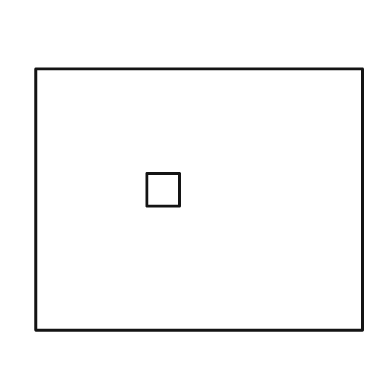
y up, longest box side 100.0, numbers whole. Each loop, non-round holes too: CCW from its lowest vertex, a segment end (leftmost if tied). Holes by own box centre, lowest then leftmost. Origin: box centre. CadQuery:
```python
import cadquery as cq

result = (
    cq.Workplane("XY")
    .moveTo(-50.0, -40.0)
    .lineTo(50.0, -40.0)
    .lineTo(50.0, 40.0)
    .lineTo(-50.0, 40.0)
    .close()
    .moveTo(-16.0, -2.0)
    .lineTo(-6.0, -2.0)
    .lineTo(-6.0, 8.0)
    .lineTo(-16.0, 8.0)
    .close()
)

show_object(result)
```